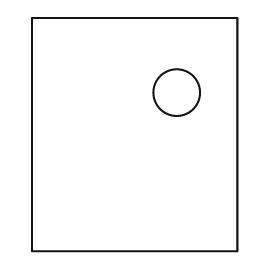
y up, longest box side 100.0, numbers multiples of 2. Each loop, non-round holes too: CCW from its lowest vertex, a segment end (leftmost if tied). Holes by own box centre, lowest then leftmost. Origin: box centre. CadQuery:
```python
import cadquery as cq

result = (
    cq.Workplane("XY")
    .moveTo(-44.0, -50.0)
    .lineTo(44.0, -50.0)
    .lineTo(44.0, 50.0)
    .lineTo(-44.0, 50.0)
    .close()
    .moveTo(18.0, 18.0)
    .circle(10.0)
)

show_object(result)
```